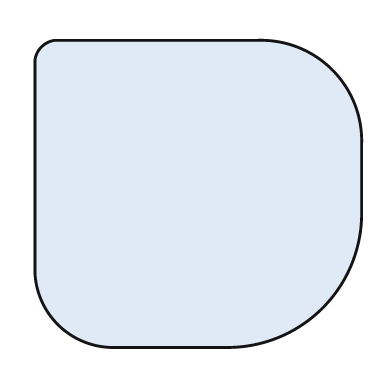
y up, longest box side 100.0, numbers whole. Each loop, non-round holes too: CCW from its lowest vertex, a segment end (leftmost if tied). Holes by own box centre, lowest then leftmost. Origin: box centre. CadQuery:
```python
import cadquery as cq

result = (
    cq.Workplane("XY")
    .moveTo(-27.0, -47.0)
    .lineTo(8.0, -47.0)
    .threePointArc((38.0, -35.0), (50.0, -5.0))
    .lineTo(50.0, 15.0)
    .threePointArc((41.0, 38.0), (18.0, 47.0))
    .lineTo(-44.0, 47.0)
    .threePointArc((-48.0, 45.0), (-50.0, 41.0))
    .lineTo(-50.0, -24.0)
    .threePointArc((-43.0, -40.0), (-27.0, -47.0))
    .close()
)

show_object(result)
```